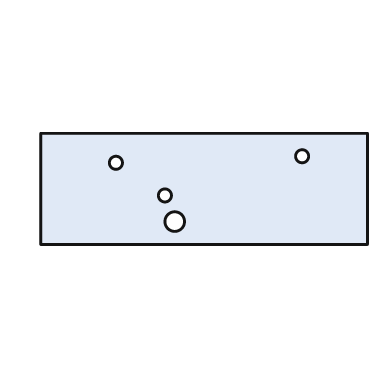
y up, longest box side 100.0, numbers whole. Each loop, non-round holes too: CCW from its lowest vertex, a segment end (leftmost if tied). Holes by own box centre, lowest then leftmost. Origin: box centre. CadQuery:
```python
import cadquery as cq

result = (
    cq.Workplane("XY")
    .moveTo(-50.0, -17.0)
    .lineTo(50.0, -17.0)
    .lineTo(50.0, 17.0)
    .lineTo(-50.0, 17.0)
    .close()
    .moveTo(-9.0, -10.0)
    .circle(3.0)
    .moveTo(-12.0, -2.0)
    .circle(2.0)
    .moveTo(-27.0, 8.0)
    .circle(2.0)
    .moveTo(30.0, 10.0)
    .circle(2.0)
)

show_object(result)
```